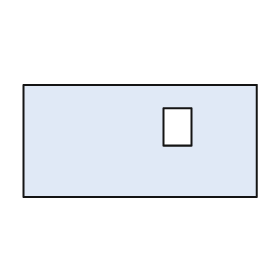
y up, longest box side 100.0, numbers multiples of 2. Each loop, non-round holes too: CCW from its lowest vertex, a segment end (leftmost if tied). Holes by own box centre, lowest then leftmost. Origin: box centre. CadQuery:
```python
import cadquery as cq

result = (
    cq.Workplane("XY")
    .moveTo(-50.0, -24.0)
    .lineTo(50.0, -24.0)
    .lineTo(50.0, 24.0)
    .lineTo(-50.0, 24.0)
    .close()
    .moveTo(10.0, -2.0)
    .lineTo(22.0, -2.0)
    .lineTo(22.0, 14.0)
    .lineTo(10.0, 14.0)
    .close()
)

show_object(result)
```